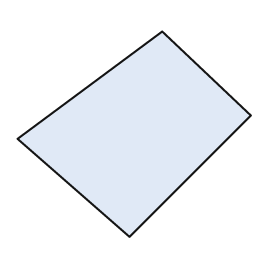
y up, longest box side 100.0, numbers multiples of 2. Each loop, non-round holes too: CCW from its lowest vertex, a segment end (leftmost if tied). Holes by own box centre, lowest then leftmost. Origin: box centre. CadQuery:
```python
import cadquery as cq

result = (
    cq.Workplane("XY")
    .moveTo(-2.0, -44.0)
    .lineTo(50.0, 8.0)
    .lineTo(12.0, 44.0)
    .lineTo(-50.0, -2.0)
    .close()
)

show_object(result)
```